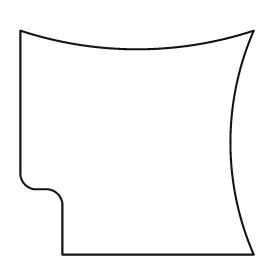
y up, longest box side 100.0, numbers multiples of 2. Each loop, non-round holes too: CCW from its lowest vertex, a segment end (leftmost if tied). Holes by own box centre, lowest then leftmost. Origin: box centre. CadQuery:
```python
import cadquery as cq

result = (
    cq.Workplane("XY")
    .moveTo(-32.0, -48.0)
    .lineTo(50.0, -48.0)
    .threePointArc((40.0, 0.0), (50.0, 48.0))
    .threePointArc((0.0, 40.0), (-50.0, 48.0))
    .lineTo(-50.0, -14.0)
    .threePointArc((-48.0, -18.0), (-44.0, -20.0))
    .lineTo(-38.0, -20.0)
    .threePointArc((-34.0, -22.0), (-32.0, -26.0))
    .close()
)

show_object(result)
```